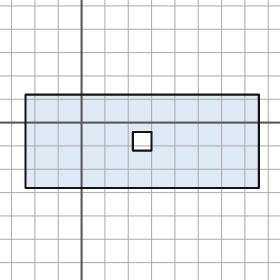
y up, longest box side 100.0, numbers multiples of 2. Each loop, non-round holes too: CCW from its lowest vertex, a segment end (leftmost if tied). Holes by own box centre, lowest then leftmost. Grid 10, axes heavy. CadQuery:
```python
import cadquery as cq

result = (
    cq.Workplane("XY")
    .moveTo(-24.0, -28.0)
    .lineTo(76.0, -28.0)
    .lineTo(76.0, 12.0)
    .lineTo(-24.0, 12.0)
    .close()
    .moveTo(22.0, -12.0)
    .lineTo(30.0, -12.0)
    .lineTo(30.0, -4.0)
    .lineTo(22.0, -4.0)
    .close()
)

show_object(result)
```